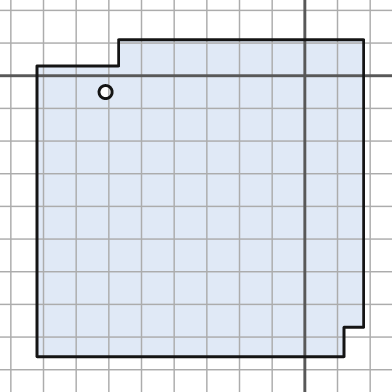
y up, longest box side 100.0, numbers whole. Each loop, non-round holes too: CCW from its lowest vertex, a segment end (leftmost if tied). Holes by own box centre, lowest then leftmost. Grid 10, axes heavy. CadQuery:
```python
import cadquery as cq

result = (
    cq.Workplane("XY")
    .moveTo(-82.0, -86.0)
    .lineTo(12.0, -86.0)
    .lineTo(12.0, -77.0)
    .lineTo(18.0, -77.0)
    .lineTo(18.0, 11.0)
    .lineTo(-57.0, 11.0)
    .lineTo(-57.0, 3.0)
    .lineTo(-82.0, 3.0)
    .close()
    .moveTo(-61.0, -5.0)
    .circle(2.0)
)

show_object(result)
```